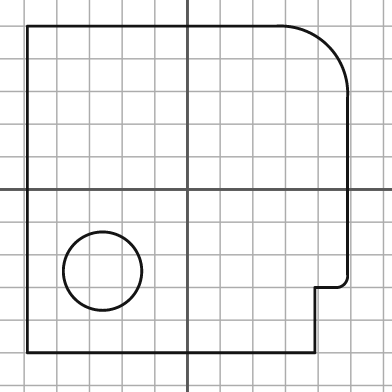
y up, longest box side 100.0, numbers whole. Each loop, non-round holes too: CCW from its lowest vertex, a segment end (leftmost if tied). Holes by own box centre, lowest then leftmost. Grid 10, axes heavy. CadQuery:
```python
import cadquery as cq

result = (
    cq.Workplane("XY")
    .moveTo(-49.0, -50.0)
    .lineTo(39.0, -50.0)
    .lineTo(39.0, -30.0)
    .lineTo(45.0, -30.0)
    .threePointArc((48.0, -29.0), (49.0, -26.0))
    .lineTo(49.0, 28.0)
    .threePointArc((43.0, 44.0), (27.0, 50.0))
    .lineTo(-49.0, 50.0)
    .close()
    .moveTo(-26.0, -25.0)
    .circle(12.0)
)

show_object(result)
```